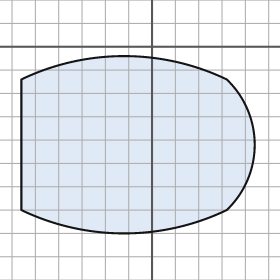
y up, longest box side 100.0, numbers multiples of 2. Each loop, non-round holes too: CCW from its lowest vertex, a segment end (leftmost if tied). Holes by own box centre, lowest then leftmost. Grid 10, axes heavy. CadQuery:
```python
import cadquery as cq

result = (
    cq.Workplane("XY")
    .moveTo(-56.0, -70.0)
    .threePointArc((-12.0, -80.0), (32.0, -70.0))
    .threePointArc((44.0, -42.0), (32.0, -14.0))
    .threePointArc((-12.0, -4.0), (-56.0, -14.0))
    .close()
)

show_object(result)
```